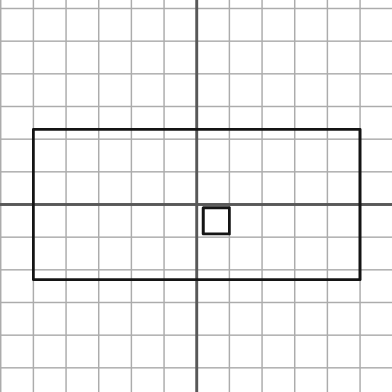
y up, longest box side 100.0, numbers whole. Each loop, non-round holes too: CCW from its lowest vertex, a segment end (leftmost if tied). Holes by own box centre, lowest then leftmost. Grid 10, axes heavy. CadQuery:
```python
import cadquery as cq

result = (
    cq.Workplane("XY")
    .moveTo(-50.0, -23.0)
    .lineTo(50.0, -23.0)
    .lineTo(50.0, 23.0)
    .lineTo(-50.0, 23.0)
    .close()
    .moveTo(2.0, -9.0)
    .lineTo(10.0, -9.0)
    .lineTo(10.0, -1.0)
    .lineTo(2.0, -1.0)
    .close()
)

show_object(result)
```